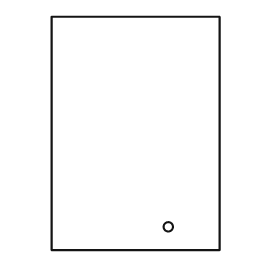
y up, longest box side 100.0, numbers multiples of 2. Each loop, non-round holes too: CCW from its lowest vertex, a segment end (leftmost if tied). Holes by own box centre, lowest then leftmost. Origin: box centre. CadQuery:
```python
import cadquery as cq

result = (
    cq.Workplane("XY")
    .moveTo(-36.0, -50.0)
    .lineTo(36.0, -50.0)
    .lineTo(36.0, 50.0)
    .lineTo(-36.0, 50.0)
    .close()
    .moveTo(14.0, -40.0)
    .circle(2.0)
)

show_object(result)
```